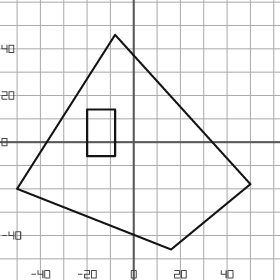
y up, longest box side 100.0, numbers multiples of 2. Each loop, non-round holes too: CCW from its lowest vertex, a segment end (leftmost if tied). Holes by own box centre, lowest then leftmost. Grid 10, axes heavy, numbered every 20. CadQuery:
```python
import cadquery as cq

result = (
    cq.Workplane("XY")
    .moveTo(16.0, -46.0)
    .lineTo(50.0, -18.0)
    .lineTo(-8.0, 46.0)
    .lineTo(-50.0, -20.0)
    .close()
    .moveTo(-20.0, -6.0)
    .lineTo(-8.0, -6.0)
    .lineTo(-8.0, 14.0)
    .lineTo(-20.0, 14.0)
    .close()
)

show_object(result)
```